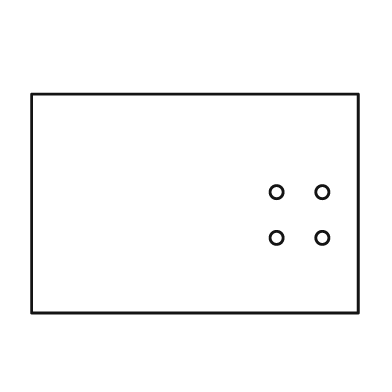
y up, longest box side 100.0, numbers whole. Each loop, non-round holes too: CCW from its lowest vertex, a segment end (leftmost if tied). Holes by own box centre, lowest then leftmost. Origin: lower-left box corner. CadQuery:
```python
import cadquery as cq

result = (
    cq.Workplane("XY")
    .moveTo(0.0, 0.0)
    .lineTo(100.0, 0.0)
    .lineTo(100.0, 67.0)
    .lineTo(0.0, 67.0)
    .close()
    .moveTo(75.0, 23.0)
    .circle(2.0)
    .moveTo(89.0, 23.0)
    .circle(2.0)
    .moveTo(75.0, 37.0)
    .circle(2.0)
    .moveTo(89.0, 37.0)
    .circle(2.0)
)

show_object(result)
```